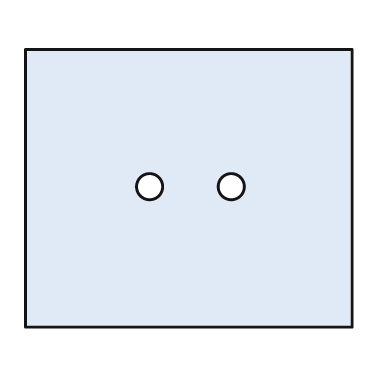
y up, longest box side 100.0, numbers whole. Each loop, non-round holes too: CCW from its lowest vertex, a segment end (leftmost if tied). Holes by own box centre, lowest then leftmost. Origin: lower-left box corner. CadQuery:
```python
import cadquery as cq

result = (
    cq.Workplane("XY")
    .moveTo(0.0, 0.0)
    .lineTo(100.0, 0.0)
    .lineTo(100.0, 85.0)
    .lineTo(0.0, 85.0)
    .close()
    .moveTo(38.0, 43.0)
    .circle(4.0)
    .moveTo(63.0, 43.0)
    .circle(4.0)
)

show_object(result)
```